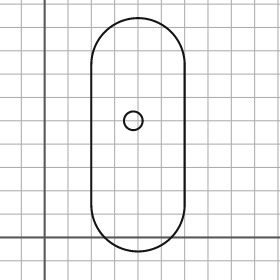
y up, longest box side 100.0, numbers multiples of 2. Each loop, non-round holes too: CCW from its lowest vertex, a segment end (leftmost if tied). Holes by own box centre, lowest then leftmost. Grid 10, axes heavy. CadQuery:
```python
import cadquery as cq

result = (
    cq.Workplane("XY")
    .moveTo(20.0, 14.0)
    .threePointArc((40.0, -6.0), (60.0, 14.0))
    .lineTo(60.0, 74.0)
    .threePointArc((40.0, 94.0), (20.0, 74.0))
    .close()
    .moveTo(38.0, 50.0)
    .circle(4.0)
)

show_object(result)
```